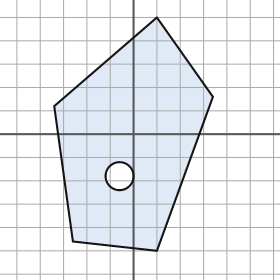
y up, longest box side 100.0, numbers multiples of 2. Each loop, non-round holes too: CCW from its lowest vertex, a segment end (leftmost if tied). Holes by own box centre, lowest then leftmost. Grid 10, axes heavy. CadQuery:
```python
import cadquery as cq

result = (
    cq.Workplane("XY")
    .moveTo(10.0, -50.0)
    .lineTo(34.0, 16.0)
    .lineTo(10.0, 50.0)
    .lineTo(-34.0, 12.0)
    .lineTo(-26.0, -46.0)
    .close()
    .moveTo(-6.0, -18.0)
    .circle(6.0)
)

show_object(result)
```